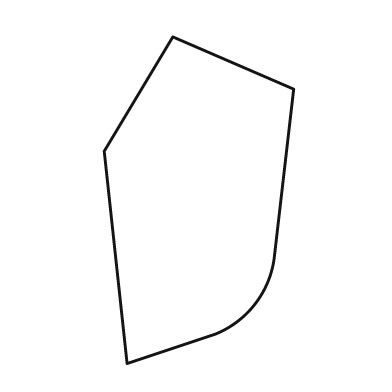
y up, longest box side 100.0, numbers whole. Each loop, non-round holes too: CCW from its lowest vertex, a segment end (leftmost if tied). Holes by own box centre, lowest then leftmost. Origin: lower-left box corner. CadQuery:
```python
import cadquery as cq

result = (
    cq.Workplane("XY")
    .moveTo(7.0, 0.0)
    .lineTo(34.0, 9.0)
    .threePointArc((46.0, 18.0), (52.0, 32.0))
    .lineTo(58.0, 84.0)
    .lineTo(21.0, 100.0)
    .lineTo(0.0, 65.0)
    .close()
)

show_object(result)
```